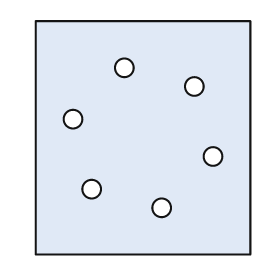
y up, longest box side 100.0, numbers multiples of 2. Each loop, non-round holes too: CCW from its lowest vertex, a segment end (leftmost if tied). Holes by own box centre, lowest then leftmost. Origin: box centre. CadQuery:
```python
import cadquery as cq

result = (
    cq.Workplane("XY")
    .moveTo(-46.0, -50.0)
    .lineTo(46.0, -50.0)
    .lineTo(46.0, 50.0)
    .lineTo(-46.0, 50.0)
    .close()
    .moveTo(8.0, -30.0)
    .circle(4.0)
    .moveTo(-22.0, -22.0)
    .circle(4.0)
    .moveTo(30.0, -8.0)
    .circle(4.0)
    .moveTo(-30.0, 8.0)
    .circle(4.0)
    .moveTo(22.0, 22.0)
    .circle(4.0)
    .moveTo(-8.0, 30.0)
    .circle(4.0)
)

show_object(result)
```